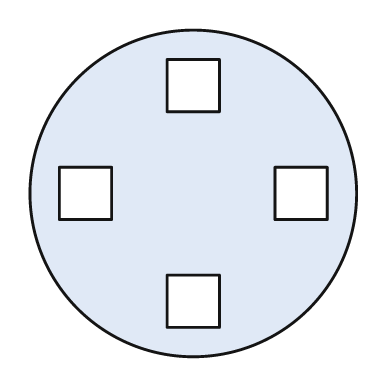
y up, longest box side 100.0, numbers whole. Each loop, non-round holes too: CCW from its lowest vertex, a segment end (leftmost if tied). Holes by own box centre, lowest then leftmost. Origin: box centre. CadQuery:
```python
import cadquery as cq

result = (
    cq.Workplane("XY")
    .moveTo(0.0, 0.0)
    .circle(50.0)
    .moveTo(-8.0, -41.0)
    .lineTo(8.0, -41.0)
    .lineTo(8.0, -25.0)
    .lineTo(-8.0, -25.0)
    .close()
    .moveTo(-41.0, -8.0)
    .lineTo(-25.0, -8.0)
    .lineTo(-25.0, 8.0)
    .lineTo(-41.0, 8.0)
    .close()
    .moveTo(25.0, -8.0)
    .lineTo(41.0, -8.0)
    .lineTo(41.0, 8.0)
    .lineTo(25.0, 8.0)
    .close()
    .moveTo(-8.0, 25.0)
    .lineTo(8.0, 25.0)
    .lineTo(8.0, 41.0)
    .lineTo(-8.0, 41.0)
    .close()
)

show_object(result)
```